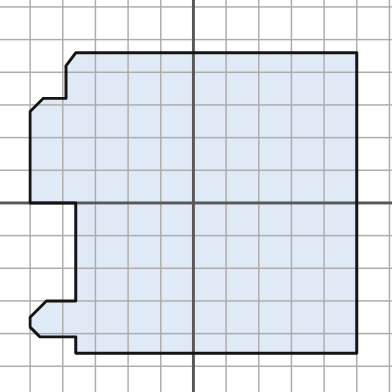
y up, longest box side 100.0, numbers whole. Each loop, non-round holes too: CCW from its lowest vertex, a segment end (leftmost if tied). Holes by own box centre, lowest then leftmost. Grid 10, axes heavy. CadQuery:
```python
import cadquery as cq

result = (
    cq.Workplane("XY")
    .moveTo(-36.0, -46.0)
    .lineTo(50.0, -46.0)
    .lineTo(50.0, 46.0)
    .lineTo(-36.0, 46.0)
    .lineTo(-39.0, 42.0)
    .lineTo(-39.0, 32.0)
    .lineTo(-46.0, 32.0)
    .lineTo(-50.0, 28.0)
    .lineTo(-50.0, 0.0)
    .lineTo(-36.0, 0.0)
    .lineTo(-36.0, -30.0)
    .lineTo(-45.0, -30.0)
    .lineTo(-50.0, -35.0)
    .lineTo(-50.0, -38.0)
    .lineTo(-47.0, -41.0)
    .lineTo(-36.0, -41.0)
    .close()
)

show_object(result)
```